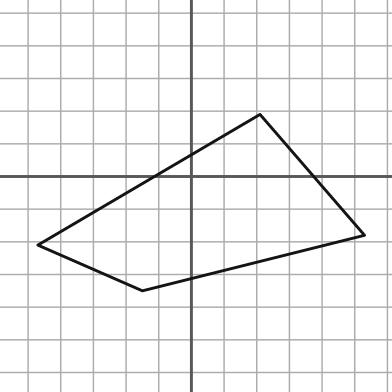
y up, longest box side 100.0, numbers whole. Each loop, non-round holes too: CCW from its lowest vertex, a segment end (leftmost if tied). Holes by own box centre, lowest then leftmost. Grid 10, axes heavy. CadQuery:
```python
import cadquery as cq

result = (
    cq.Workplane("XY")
    .moveTo(-15.0, -35.0)
    .lineTo(53.0, -18.0)
    .lineTo(21.0, 19.0)
    .lineTo(-47.0, -21.0)
    .close()
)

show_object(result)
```